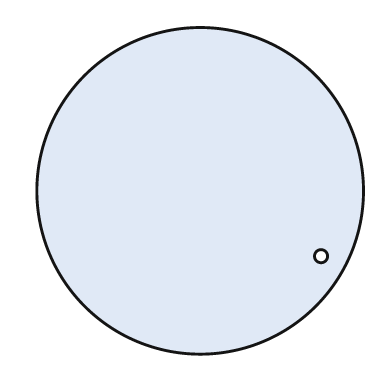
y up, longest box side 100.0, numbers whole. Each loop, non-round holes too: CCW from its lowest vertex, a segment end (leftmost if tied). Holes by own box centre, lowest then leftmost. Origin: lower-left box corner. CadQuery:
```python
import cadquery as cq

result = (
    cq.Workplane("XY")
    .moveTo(50.0, 50.0)
    .circle(50.0)
    .moveTo(87.0, 30.0)
    .circle(2.0)
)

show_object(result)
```